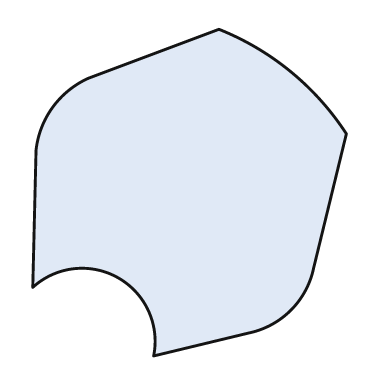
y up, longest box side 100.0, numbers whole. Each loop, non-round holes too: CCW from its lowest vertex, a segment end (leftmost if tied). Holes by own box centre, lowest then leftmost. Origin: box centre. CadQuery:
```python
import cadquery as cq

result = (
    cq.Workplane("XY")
    .moveTo(-11.0, -50.0)
    .lineTo(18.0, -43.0)
    .threePointArc((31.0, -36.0), (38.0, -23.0))
    .lineTo(48.0, 18.0)
    .threePointArc((31.0, 37.0), (9.0, 50.0))
    .lineTo(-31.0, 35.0)
    .threePointArc((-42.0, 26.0), (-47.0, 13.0))
    .lineTo(-48.0, -29.0)
    .threePointArc((-22.0, -26.0), (-11.0, -50.0))
    .close()
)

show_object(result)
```